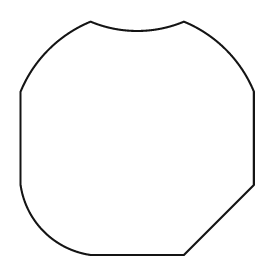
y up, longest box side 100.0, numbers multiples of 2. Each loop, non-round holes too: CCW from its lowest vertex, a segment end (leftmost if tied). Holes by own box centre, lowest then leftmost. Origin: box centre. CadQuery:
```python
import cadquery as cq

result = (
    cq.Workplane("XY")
    .moveTo(-20.0, -50.0)
    .lineTo(20.0, -50.0)
    .lineTo(50.0, -20.0)
    .lineTo(50.0, 20.0)
    .threePointArc((38.0, 38.0), (20.0, 50.0))
    .threePointArc((0.0, 46.0), (-20.0, 50.0))
    .threePointArc((-38.0, 38.0), (-50.0, 20.0))
    .lineTo(-50.0, -20.0)
    .threePointArc((-40.0, -40.0), (-20.0, -50.0))
    .close()
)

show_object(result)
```